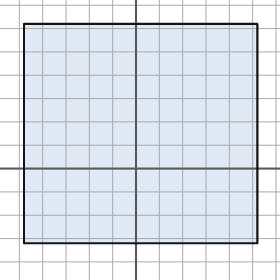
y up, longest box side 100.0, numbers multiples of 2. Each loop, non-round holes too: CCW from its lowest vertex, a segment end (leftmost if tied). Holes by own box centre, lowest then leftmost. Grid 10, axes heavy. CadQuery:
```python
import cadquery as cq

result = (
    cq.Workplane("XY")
    .moveTo(-48.0, -32.0)
    .lineTo(52.0, -32.0)
    .lineTo(52.0, 62.0)
    .lineTo(-48.0, 62.0)
    .close()
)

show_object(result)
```